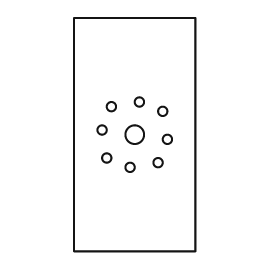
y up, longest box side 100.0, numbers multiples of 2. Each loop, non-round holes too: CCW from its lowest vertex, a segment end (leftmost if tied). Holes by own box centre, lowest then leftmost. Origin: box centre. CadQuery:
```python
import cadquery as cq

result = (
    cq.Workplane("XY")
    .moveTo(-26.0, -50.0)
    .lineTo(26.0, -50.0)
    .lineTo(26.0, 50.0)
    .lineTo(-26.0, 50.0)
    .close()
    .moveTo(-2.0, -14.0)
    .circle(2.0)
    .moveTo(10.0, -12.0)
    .circle(2.0)
    .moveTo(-12.0, -10.0)
    .circle(2.0)
    .moveTo(14.0, -2.0)
    .circle(2.0)
    .moveTo(0.0, 0.0)
    .circle(4.0)
    .moveTo(-14.0, 2.0)
    .circle(2.0)
    .moveTo(12.0, 10.0)
    .circle(2.0)
    .moveTo(-10.0, 12.0)
    .circle(2.0)
    .moveTo(2.0, 14.0)
    .circle(2.0)
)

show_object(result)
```